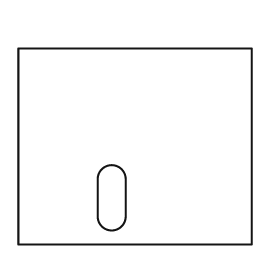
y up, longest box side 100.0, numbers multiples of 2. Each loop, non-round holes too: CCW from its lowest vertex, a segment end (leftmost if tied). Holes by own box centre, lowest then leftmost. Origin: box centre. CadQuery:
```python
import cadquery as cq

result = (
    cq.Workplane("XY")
    .moveTo(-50.0, -42.0)
    .lineTo(50.0, -42.0)
    .lineTo(50.0, 42.0)
    .lineTo(-50.0, 42.0)
    .close()
    .moveTo(-16.0, -30.0)
    .threePointArc((-10.0, -36.0), (-4.0, -30.0))
    .lineTo(-4.0, -14.0)
    .threePointArc((-10.0, -8.0), (-16.0, -14.0))
    .close()
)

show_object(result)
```